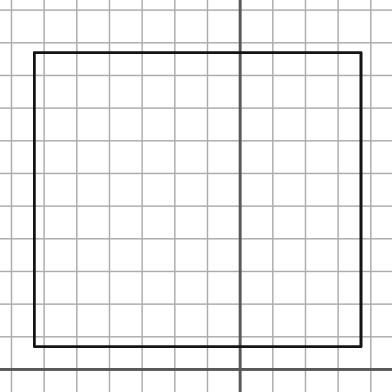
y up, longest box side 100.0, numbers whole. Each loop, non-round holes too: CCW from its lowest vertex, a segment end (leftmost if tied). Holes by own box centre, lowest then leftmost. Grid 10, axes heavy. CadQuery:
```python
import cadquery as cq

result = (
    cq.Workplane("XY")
    .moveTo(-63.0, 7.0)
    .lineTo(37.0, 7.0)
    .lineTo(37.0, 97.0)
    .lineTo(-63.0, 97.0)
    .close()
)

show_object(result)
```